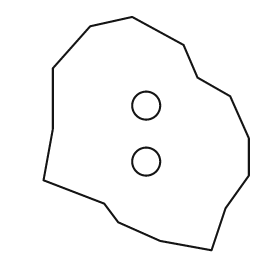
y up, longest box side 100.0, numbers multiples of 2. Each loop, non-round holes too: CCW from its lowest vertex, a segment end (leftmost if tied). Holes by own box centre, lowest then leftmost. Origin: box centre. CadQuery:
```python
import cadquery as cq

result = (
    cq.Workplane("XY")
    .moveTo(28.0, -50.0)
    .lineTo(34.0, -32.0)
    .lineTo(44.0, -18.0)
    .lineTo(44.0, -2.0)
    .lineTo(36.0, 16.0)
    .lineTo(22.0, 24.0)
    .lineTo(16.0, 38.0)
    .lineTo(-6.0, 50.0)
    .lineTo(-24.0, 46.0)
    .lineTo(-40.0, 28.0)
    .lineTo(-40.0, 2.0)
    .lineTo(-44.0, -20.0)
    .lineTo(-18.0, -30.0)
    .lineTo(-12.0, -38.0)
    .lineTo(6.0, -46.0)
    .close()
    .moveTo(0.0, -12.0)
    .circle(6.0)
    .moveTo(0.0, 12.0)
    .circle(6.0)
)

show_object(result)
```